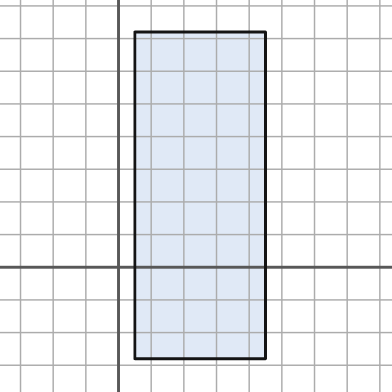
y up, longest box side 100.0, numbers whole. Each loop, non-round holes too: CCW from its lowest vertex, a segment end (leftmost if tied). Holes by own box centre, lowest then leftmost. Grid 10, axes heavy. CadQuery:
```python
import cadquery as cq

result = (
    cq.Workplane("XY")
    .moveTo(5.0, -28.0)
    .lineTo(45.0, -28.0)
    .lineTo(45.0, 72.0)
    .lineTo(5.0, 72.0)
    .close()
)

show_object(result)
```